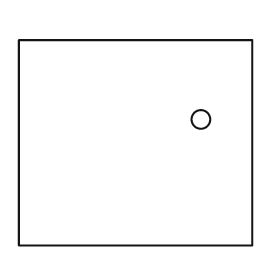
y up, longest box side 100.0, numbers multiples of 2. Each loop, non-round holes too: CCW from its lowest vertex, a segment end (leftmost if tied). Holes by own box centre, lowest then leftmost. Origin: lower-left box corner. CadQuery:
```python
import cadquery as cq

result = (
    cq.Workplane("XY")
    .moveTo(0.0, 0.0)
    .lineTo(100.0, 0.0)
    .lineTo(100.0, 88.0)
    .lineTo(0.0, 88.0)
    .close()
    .moveTo(78.0, 54.0)
    .circle(4.0)
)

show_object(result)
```